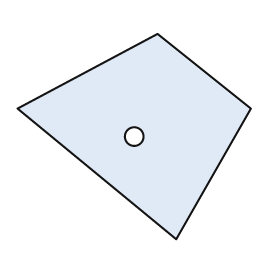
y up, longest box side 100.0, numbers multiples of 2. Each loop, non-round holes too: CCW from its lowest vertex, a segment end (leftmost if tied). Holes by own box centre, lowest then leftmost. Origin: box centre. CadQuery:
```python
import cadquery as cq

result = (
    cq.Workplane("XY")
    .moveTo(18.0, -44.0)
    .lineTo(50.0, 12.0)
    .lineTo(10.0, 44.0)
    .lineTo(-50.0, 12.0)
    .close()
    .moveTo(0.0, 0.0)
    .circle(4.0)
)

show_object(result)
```